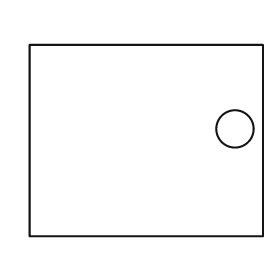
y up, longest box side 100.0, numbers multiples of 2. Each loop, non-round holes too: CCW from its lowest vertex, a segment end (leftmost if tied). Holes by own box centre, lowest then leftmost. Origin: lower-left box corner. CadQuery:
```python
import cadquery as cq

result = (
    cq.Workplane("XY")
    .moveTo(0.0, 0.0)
    .lineTo(100.0, 0.0)
    .lineTo(100.0, 82.0)
    .lineTo(0.0, 82.0)
    .close()
    .moveTo(88.0, 46.0)
    .circle(8.0)
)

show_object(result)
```